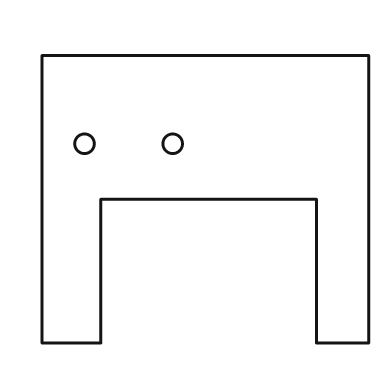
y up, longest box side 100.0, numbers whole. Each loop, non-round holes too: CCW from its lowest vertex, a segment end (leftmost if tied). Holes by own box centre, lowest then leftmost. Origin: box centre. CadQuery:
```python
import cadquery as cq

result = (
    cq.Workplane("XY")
    .moveTo(-50.0, -44.0)
    .lineTo(-32.0, -44.0)
    .lineTo(-32.0, 0.0)
    .lineTo(34.0, 0.0)
    .lineTo(34.0, -44.0)
    .lineTo(50.0, -44.0)
    .lineTo(50.0, 44.0)
    .lineTo(-50.0, 44.0)
    .close()
    .moveTo(-37.0, 17.0)
    .circle(3.0)
    .moveTo(-10.0, 17.0)
    .circle(3.0)
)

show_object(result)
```